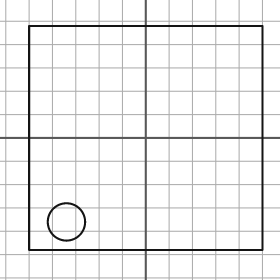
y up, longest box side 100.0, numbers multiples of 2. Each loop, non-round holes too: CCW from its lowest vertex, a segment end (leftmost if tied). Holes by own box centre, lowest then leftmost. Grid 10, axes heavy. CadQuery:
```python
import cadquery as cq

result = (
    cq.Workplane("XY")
    .moveTo(-50.0, -48.0)
    .lineTo(50.0, -48.0)
    .lineTo(50.0, 48.0)
    .lineTo(-50.0, 48.0)
    .close()
    .moveTo(-34.0, -36.0)
    .circle(8.0)
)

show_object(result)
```